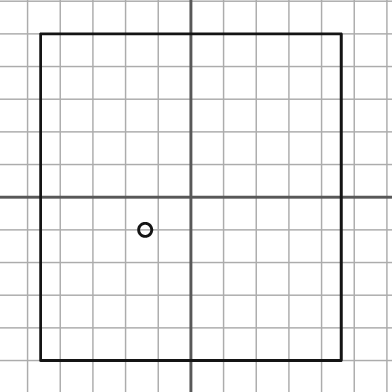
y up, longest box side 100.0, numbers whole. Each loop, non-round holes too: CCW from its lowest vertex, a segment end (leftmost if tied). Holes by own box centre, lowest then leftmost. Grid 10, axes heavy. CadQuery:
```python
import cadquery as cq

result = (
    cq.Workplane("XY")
    .moveTo(-46.0, -50.0)
    .lineTo(46.0, -50.0)
    .lineTo(46.0, 50.0)
    .lineTo(-46.0, 50.0)
    .close()
    .moveTo(-14.0, -10.0)
    .circle(2.0)
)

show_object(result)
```